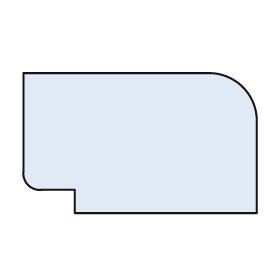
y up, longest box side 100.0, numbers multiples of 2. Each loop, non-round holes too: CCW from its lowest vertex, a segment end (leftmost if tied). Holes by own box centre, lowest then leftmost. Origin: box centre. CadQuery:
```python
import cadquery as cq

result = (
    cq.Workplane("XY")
    .moveTo(-28.0, -30.0)
    .lineTo(50.0, -30.0)
    .lineTo(50.0, 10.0)
    .threePointArc((44.0, 24.0), (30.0, 30.0))
    .lineTo(-50.0, 30.0)
    .lineTo(-50.0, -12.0)
    .threePointArc((-48.0, -18.0), (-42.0, -20.0))
    .lineTo(-28.0, -20.0)
    .close()
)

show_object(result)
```